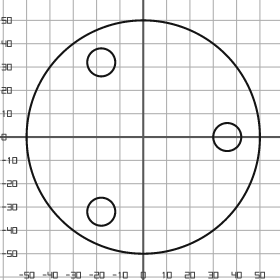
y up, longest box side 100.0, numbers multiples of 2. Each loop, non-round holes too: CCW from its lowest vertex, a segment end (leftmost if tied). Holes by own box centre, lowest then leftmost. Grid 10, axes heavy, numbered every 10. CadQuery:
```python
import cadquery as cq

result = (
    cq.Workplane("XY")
    .moveTo(0.0, 0.0)
    .circle(50.0)
    .moveTo(-18.0, -32.0)
    .circle(6.0)
    .moveTo(36.0, 0.0)
    .circle(6.0)
    .moveTo(-18.0, 32.0)
    .circle(6.0)
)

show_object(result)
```